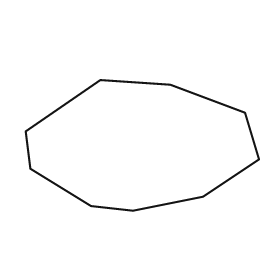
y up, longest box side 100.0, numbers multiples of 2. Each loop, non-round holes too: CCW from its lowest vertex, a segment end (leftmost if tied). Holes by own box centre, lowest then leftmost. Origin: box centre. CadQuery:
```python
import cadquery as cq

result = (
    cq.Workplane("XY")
    .moveTo(-4.0, -28.0)
    .lineTo(26.0, -22.0)
    .lineTo(50.0, -6.0)
    .lineTo(44.0, 14.0)
    .lineTo(12.0, 26.0)
    .lineTo(-18.0, 28.0)
    .lineTo(-50.0, 6.0)
    .lineTo(-48.0, -10.0)
    .lineTo(-22.0, -26.0)
    .close()
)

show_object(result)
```